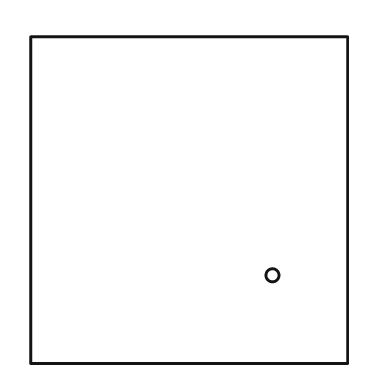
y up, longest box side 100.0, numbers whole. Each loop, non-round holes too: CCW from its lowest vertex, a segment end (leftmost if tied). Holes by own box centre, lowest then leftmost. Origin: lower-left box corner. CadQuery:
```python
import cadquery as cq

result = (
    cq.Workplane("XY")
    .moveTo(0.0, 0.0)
    .lineTo(97.0, 0.0)
    .lineTo(97.0, 100.0)
    .lineTo(0.0, 100.0)
    .close()
    .moveTo(74.0, 27.0)
    .circle(2.0)
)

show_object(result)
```